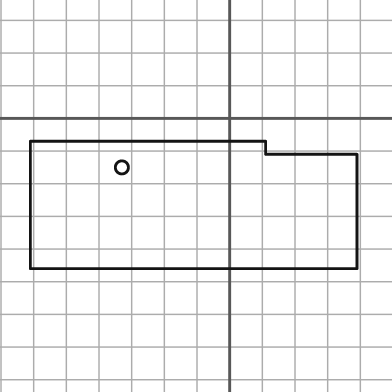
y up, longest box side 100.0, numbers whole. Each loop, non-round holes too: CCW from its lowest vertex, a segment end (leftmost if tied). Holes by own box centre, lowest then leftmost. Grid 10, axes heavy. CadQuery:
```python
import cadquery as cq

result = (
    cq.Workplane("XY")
    .moveTo(-61.0, -46.0)
    .lineTo(39.0, -46.0)
    .lineTo(39.0, -11.0)
    .lineTo(11.0, -11.0)
    .lineTo(11.0, -7.0)
    .lineTo(-61.0, -7.0)
    .close()
    .moveTo(-33.0, -15.0)
    .circle(2.0)
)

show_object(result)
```